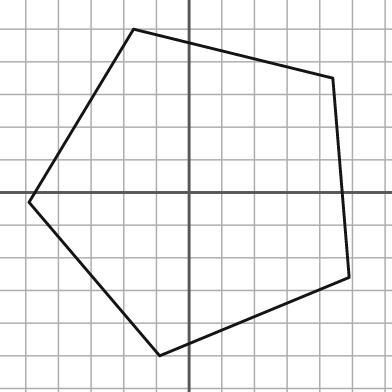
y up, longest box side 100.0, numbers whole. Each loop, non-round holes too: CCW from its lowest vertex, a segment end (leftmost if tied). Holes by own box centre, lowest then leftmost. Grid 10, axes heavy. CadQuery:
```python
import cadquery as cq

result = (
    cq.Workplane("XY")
    .moveTo(-9.0, -50.0)
    .lineTo(49.0, -26.0)
    .lineTo(44.0, 35.0)
    .lineTo(-17.0, 50.0)
    .lineTo(-49.0, -3.0)
    .close()
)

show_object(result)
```